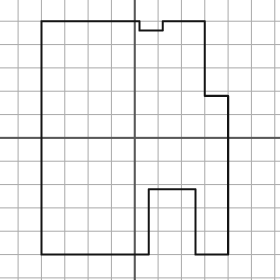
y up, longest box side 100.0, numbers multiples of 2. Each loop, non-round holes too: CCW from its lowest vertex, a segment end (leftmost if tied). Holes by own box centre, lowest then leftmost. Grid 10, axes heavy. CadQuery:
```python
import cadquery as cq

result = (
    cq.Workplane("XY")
    .moveTo(-40.0, -50.0)
    .lineTo(6.0, -50.0)
    .lineTo(6.0, -22.0)
    .lineTo(26.0, -22.0)
    .lineTo(26.0, -50.0)
    .lineTo(40.0, -50.0)
    .lineTo(40.0, 18.0)
    .lineTo(30.0, 18.0)
    .lineTo(30.0, 50.0)
    .lineTo(12.0, 50.0)
    .lineTo(12.0, 46.0)
    .lineTo(2.0, 46.0)
    .lineTo(2.0, 50.0)
    .lineTo(-40.0, 50.0)
    .close()
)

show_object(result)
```